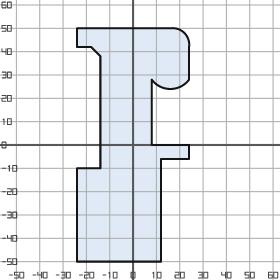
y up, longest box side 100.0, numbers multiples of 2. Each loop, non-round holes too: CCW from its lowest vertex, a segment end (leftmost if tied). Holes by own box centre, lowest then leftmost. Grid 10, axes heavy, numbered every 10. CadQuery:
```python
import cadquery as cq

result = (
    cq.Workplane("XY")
    .moveTo(-24.0, -50.0)
    .lineTo(12.0, -50.0)
    .lineTo(12.0, -6.0)
    .lineTo(24.0, -6.0)
    .lineTo(24.0, 0.0)
    .lineTo(8.0, 0.0)
    .lineTo(8.0, 28.0)
    .threePointArc((16.0, 24.0), (24.0, 28.0))
    .lineTo(24.0, 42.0)
    .threePointArc((22.0, 48.0), (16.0, 50.0))
    .lineTo(-24.0, 50.0)
    .lineTo(-24.0, 42.0)
    .lineTo(-18.0, 42.0)
    .lineTo(-14.0, 38.0)
    .lineTo(-14.0, -10.0)
    .lineTo(-24.0, -10.0)
    .close()
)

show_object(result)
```